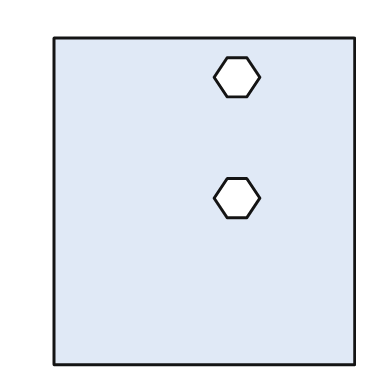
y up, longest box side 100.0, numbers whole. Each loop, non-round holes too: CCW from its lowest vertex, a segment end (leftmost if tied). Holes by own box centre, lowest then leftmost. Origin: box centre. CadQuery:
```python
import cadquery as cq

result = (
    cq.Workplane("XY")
    .moveTo(-46.0, -50.0)
    .lineTo(46.0, -50.0)
    .lineTo(46.0, 50.0)
    .lineTo(-46.0, 50.0)
    .close()
    .moveTo(7.0, -5.0)
    .lineTo(13.0, -5.0)
    .lineTo(17.0, 1.0)
    .lineTo(13.0, 7.0)
    .lineTo(7.0, 7.0)
    .lineTo(3.0, 1.0)
    .close()
    .moveTo(7.0, 32.0)
    .lineTo(13.0, 32.0)
    .lineTo(17.0, 38.0)
    .lineTo(13.0, 44.0)
    .lineTo(7.0, 44.0)
    .lineTo(3.0, 38.0)
    .close()
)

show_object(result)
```